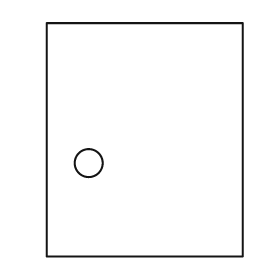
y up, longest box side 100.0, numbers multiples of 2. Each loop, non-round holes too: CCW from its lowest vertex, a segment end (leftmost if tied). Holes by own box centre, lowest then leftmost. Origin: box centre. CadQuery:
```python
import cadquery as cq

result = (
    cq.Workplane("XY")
    .moveTo(-42.0, -50.0)
    .lineTo(42.0, -50.0)
    .lineTo(42.0, 50.0)
    .lineTo(-42.0, 50.0)
    .close()
    .moveTo(-24.0, -10.0)
    .circle(6.0)
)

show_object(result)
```